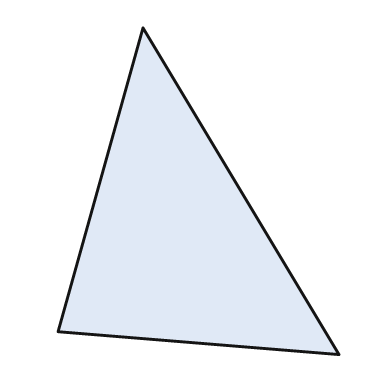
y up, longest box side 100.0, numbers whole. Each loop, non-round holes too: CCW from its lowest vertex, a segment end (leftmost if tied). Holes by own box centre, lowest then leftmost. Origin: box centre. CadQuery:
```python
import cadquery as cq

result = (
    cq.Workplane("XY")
    .moveTo(43.0, -50.0)
    .lineTo(-17.0, 50.0)
    .lineTo(-43.0, -43.0)
    .close()
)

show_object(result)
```